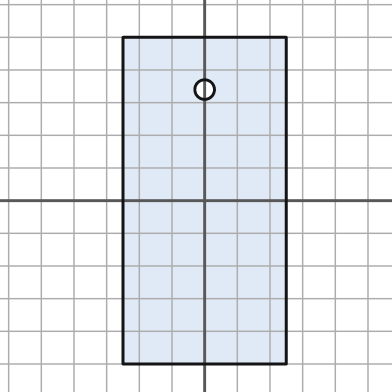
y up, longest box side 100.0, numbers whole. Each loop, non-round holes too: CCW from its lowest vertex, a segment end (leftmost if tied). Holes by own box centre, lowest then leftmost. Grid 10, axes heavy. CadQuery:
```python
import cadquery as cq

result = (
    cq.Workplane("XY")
    .moveTo(-25.0, -50.0)
    .lineTo(25.0, -50.0)
    .lineTo(25.0, 50.0)
    .lineTo(-25.0, 50.0)
    .close()
    .moveTo(0.0, 34.0)
    .circle(3.0)
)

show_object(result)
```